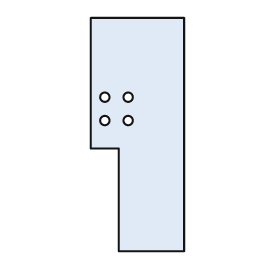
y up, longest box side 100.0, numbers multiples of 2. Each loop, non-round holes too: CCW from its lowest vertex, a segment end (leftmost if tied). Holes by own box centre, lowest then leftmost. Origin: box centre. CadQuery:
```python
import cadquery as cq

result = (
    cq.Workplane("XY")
    .moveTo(-8.0, -50.0)
    .lineTo(20.0, -50.0)
    .lineTo(20.0, 50.0)
    .lineTo(-20.0, 50.0)
    .lineTo(-20.0, -6.0)
    .lineTo(-8.0, -6.0)
    .close()
    .moveTo(-14.0, 6.0)
    .circle(2.0)
    .moveTo(-4.0, 6.0)
    .circle(2.0)
    .moveTo(-14.0, 16.0)
    .circle(2.0)
    .moveTo(-4.0, 16.0)
    .circle(2.0)
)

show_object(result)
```